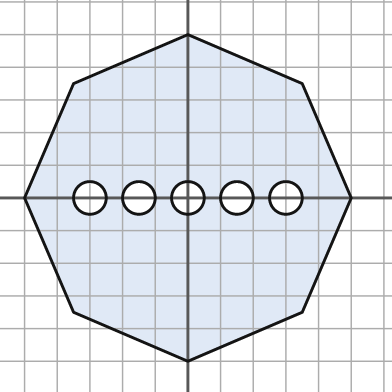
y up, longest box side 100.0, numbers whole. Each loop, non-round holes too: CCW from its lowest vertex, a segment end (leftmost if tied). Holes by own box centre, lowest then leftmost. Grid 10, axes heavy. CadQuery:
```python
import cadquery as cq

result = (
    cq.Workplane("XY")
    .moveTo(0.0, -50.0)
    .lineTo(35.0, -35.0)
    .lineTo(50.0, 0.0)
    .lineTo(35.0, 35.0)
    .lineTo(0.0, 50.0)
    .lineTo(-35.0, 35.0)
    .lineTo(-50.0, 0.0)
    .lineTo(-35.0, -35.0)
    .close()
    .moveTo(-30.0, 0.0)
    .circle(5.0)
    .moveTo(-15.0, 0.0)
    .circle(5.0)
    .moveTo(0.0, 0.0)
    .circle(5.0)
    .moveTo(15.0, 0.0)
    .circle(5.0)
    .moveTo(30.0, 0.0)
    .circle(5.0)
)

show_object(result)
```